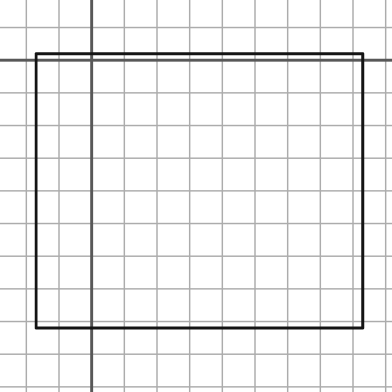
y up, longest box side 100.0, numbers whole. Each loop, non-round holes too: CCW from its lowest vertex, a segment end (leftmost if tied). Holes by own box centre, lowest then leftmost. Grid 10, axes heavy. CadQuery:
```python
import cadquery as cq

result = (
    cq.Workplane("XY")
    .moveTo(-17.0, -82.0)
    .lineTo(83.0, -82.0)
    .lineTo(83.0, 2.0)
    .lineTo(-17.0, 2.0)
    .close()
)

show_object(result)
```